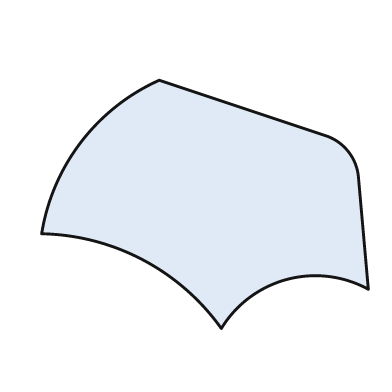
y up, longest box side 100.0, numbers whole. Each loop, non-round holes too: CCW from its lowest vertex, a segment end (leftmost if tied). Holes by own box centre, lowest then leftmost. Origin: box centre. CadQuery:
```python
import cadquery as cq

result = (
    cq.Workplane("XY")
    .moveTo(5.0, -38.0)
    .threePointArc((25.0, -23.0), (50.0, -26.0))
    .lineTo(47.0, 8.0)
    .threePointArc((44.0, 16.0), (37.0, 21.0))
    .lineTo(-14.0, 38.0)
    .threePointArc((-38.0, 19.0), (-50.0, -9.0))
    .threePointArc((-19.0, -17.0), (5.0, -38.0))
    .close()
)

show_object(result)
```